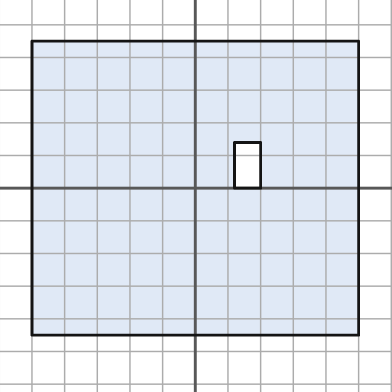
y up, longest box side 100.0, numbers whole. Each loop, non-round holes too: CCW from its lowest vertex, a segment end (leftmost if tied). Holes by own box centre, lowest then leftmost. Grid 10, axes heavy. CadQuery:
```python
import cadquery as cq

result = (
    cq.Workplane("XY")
    .moveTo(-50.0, -45.0)
    .lineTo(50.0, -45.0)
    .lineTo(50.0, 45.0)
    .lineTo(-50.0, 45.0)
    .close()
    .moveTo(12.0, 0.0)
    .lineTo(20.0, 0.0)
    .lineTo(20.0, 14.0)
    .lineTo(12.0, 14.0)
    .close()
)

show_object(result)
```